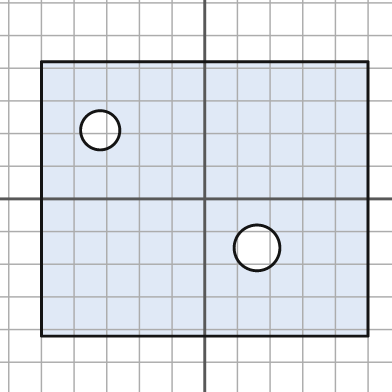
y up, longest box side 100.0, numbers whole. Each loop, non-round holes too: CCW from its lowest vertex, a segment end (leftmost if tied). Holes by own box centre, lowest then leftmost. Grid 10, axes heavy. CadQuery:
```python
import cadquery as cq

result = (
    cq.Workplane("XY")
    .moveTo(-50.0, -42.0)
    .lineTo(50.0, -42.0)
    .lineTo(50.0, 42.0)
    .lineTo(-50.0, 42.0)
    .close()
    .moveTo(16.0, -15.0)
    .circle(7.0)
    .moveTo(-32.0, 21.0)
    .circle(6.0)
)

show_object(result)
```